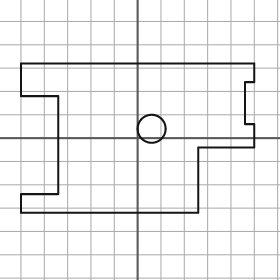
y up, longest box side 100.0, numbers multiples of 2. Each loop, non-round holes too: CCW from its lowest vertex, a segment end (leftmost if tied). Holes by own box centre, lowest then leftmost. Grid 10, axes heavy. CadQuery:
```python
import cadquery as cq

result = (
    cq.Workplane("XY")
    .moveTo(-50.0, -32.0)
    .lineTo(26.0, -32.0)
    .lineTo(26.0, -4.0)
    .lineTo(50.0, -4.0)
    .lineTo(50.0, 6.0)
    .lineTo(46.0, 6.0)
    .lineTo(46.0, 24.0)
    .lineTo(50.0, 24.0)
    .lineTo(50.0, 32.0)
    .lineTo(-50.0, 32.0)
    .lineTo(-50.0, 18.0)
    .lineTo(-34.0, 18.0)
    .lineTo(-34.0, -24.0)
    .lineTo(-50.0, -24.0)
    .close()
    .moveTo(6.0, 4.0)
    .circle(6.0)
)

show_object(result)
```